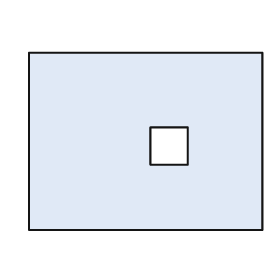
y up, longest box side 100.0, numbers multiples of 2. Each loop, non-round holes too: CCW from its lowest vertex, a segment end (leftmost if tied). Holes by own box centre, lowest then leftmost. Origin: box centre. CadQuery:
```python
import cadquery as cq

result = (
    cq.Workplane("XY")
    .moveTo(-50.0, -38.0)
    .lineTo(50.0, -38.0)
    .lineTo(50.0, 38.0)
    .lineTo(-50.0, 38.0)
    .close()
    .moveTo(2.0, -10.0)
    .lineTo(18.0, -10.0)
    .lineTo(18.0, 6.0)
    .lineTo(2.0, 6.0)
    .close()
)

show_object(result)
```